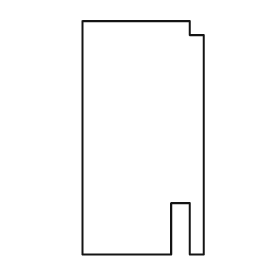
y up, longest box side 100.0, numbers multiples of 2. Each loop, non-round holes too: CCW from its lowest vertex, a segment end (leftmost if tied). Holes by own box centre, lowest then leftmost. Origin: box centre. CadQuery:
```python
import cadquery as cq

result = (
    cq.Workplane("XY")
    .moveTo(-26.0, -50.0)
    .lineTo(12.0, -50.0)
    .lineTo(12.0, -28.0)
    .lineTo(20.0, -28.0)
    .lineTo(20.0, -50.0)
    .lineTo(26.0, -50.0)
    .lineTo(26.0, 44.0)
    .lineTo(20.0, 44.0)
    .lineTo(20.0, 50.0)
    .lineTo(-26.0, 50.0)
    .close()
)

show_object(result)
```